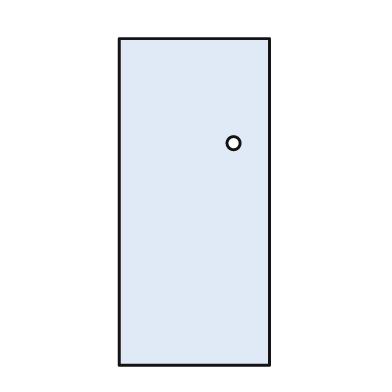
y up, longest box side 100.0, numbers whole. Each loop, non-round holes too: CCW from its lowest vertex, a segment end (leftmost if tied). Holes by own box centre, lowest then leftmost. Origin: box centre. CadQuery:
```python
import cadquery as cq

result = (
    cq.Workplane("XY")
    .moveTo(-23.0, -50.0)
    .lineTo(23.0, -50.0)
    .lineTo(23.0, 50.0)
    .lineTo(-23.0, 50.0)
    .close()
    .moveTo(12.0, 18.0)
    .circle(2.0)
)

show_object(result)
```